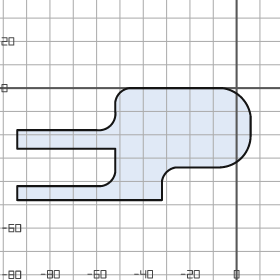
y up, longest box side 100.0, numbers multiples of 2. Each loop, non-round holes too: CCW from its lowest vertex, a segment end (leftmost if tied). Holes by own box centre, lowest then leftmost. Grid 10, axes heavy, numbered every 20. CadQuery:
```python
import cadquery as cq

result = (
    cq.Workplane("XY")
    .moveTo(-94.0, -48.0)
    .lineTo(-32.0, -48.0)
    .lineTo(-32.0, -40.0)
    .threePointArc((-30.0, -36.0), (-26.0, -34.0))
    .lineTo(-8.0, -34.0)
    .threePointArc((2.0, -30.0), (6.0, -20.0))
    .lineTo(6.0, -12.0)
    .threePointArc((2.0, -4.0), (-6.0, 0.0))
    .lineTo(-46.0, 0.0)
    .threePointArc((-50.0, -2.0), (-52.0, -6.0))
    .lineTo(-52.0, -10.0)
    .threePointArc((-54.0, -16.0), (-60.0, -18.0))
    .lineTo(-94.0, -18.0)
    .lineTo(-94.0, -26.0)
    .lineTo(-52.0, -26.0)
    .lineTo(-52.0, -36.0)
    .threePointArc((-54.0, -40.0), (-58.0, -42.0))
    .lineTo(-94.0, -42.0)
    .close()
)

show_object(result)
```